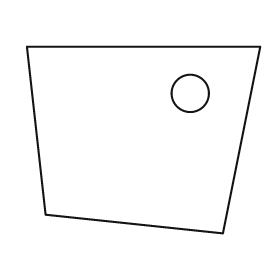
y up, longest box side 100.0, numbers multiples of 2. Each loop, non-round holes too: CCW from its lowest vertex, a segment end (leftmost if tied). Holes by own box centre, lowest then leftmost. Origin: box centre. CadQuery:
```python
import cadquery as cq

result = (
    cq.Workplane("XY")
    .moveTo(34.0, -40.0)
    .lineTo(50.0, 40.0)
    .lineTo(-50.0, 40.0)
    .lineTo(-42.0, -32.0)
    .close()
    .moveTo(20.0, 20.0)
    .circle(8.0)
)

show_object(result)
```